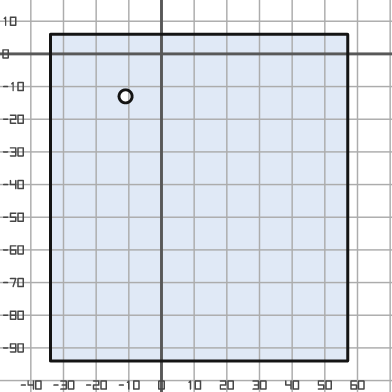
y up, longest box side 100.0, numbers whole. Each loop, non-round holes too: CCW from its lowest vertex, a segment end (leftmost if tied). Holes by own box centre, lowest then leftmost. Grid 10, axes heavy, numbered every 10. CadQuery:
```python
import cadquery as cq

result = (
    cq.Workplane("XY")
    .moveTo(-34.0, -94.0)
    .lineTo(57.0, -94.0)
    .lineTo(57.0, 6.0)
    .lineTo(-34.0, 6.0)
    .close()
    .moveTo(-11.0, -13.0)
    .circle(2.0)
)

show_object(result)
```